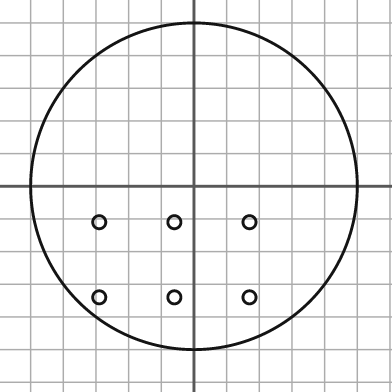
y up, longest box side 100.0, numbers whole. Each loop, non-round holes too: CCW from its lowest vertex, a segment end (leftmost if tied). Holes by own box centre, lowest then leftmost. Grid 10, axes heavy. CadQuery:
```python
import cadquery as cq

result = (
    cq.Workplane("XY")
    .moveTo(0.0, 0.0)
    .circle(50.0)
    .moveTo(-29.0, -34.0)
    .circle(2.0)
    .moveTo(-6.0, -34.0)
    .circle(2.0)
    .moveTo(17.0, -34.0)
    .circle(2.0)
    .moveTo(-29.0, -11.0)
    .circle(2.0)
    .moveTo(-6.0, -11.0)
    .circle(2.0)
    .moveTo(17.0, -11.0)
    .circle(2.0)
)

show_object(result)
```